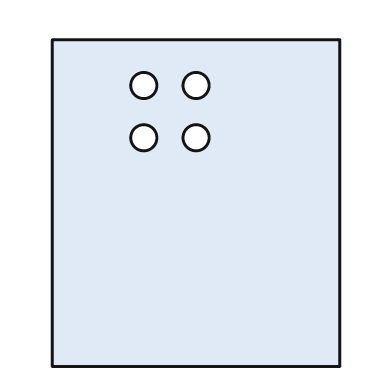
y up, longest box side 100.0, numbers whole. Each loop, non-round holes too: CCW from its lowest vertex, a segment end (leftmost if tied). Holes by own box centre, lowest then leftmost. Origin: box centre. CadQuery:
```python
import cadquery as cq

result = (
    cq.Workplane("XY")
    .moveTo(-44.0, -50.0)
    .lineTo(44.0, -50.0)
    .lineTo(44.0, 50.0)
    .lineTo(-44.0, 50.0)
    .close()
    .moveTo(-16.0, 20.0)
    .circle(4.0)
    .moveTo(0.0, 20.0)
    .circle(4.0)
    .moveTo(-16.0, 36.0)
    .circle(4.0)
    .moveTo(0.0, 36.0)
    .circle(4.0)
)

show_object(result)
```